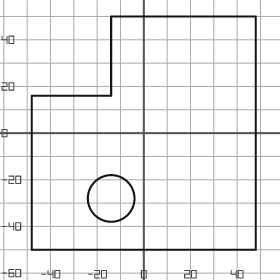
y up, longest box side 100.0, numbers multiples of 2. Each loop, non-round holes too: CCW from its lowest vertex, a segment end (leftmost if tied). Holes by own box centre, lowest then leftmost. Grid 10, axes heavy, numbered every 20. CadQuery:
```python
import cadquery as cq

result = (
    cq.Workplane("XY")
    .moveTo(-48.0, -50.0)
    .lineTo(48.0, -50.0)
    .lineTo(48.0, 50.0)
    .lineTo(-14.0, 50.0)
    .lineTo(-14.0, 16.0)
    .lineTo(-48.0, 16.0)
    .close()
    .moveTo(-14.0, -28.0)
    .circle(10.0)
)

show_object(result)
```